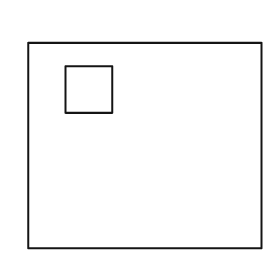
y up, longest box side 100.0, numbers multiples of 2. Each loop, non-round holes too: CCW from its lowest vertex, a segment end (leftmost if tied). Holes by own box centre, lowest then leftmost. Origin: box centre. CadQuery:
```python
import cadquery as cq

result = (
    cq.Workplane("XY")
    .moveTo(-50.0, -44.0)
    .lineTo(50.0, -44.0)
    .lineTo(50.0, 44.0)
    .lineTo(-50.0, 44.0)
    .close()
    .moveTo(-34.0, 14.0)
    .lineTo(-14.0, 14.0)
    .lineTo(-14.0, 34.0)
    .lineTo(-34.0, 34.0)
    .close()
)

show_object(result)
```